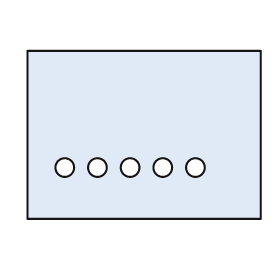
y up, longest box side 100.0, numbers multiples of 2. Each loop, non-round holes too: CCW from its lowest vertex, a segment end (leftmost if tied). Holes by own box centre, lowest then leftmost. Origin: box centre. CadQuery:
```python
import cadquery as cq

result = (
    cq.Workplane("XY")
    .moveTo(-50.0, -36.0)
    .lineTo(50.0, -36.0)
    .lineTo(50.0, 36.0)
    .lineTo(-50.0, 36.0)
    .close()
    .moveTo(-34.0, -14.0)
    .circle(4.0)
    .moveTo(-20.0, -14.0)
    .circle(4.0)
    .moveTo(-6.0, -14.0)
    .circle(4.0)
    .moveTo(8.0, -14.0)
    .circle(4.0)
    .moveTo(22.0, -14.0)
    .circle(4.0)
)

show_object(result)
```